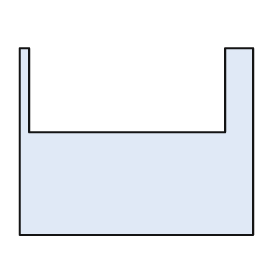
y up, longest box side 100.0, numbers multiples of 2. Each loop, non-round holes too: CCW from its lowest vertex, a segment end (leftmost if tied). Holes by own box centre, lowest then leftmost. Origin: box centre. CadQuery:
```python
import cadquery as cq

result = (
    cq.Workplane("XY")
    .moveTo(-50.0, -40.0)
    .lineTo(50.0, -40.0)
    .lineTo(50.0, 40.0)
    .lineTo(38.0, 40.0)
    .lineTo(38.0, 4.0)
    .lineTo(-46.0, 4.0)
    .lineTo(-46.0, 40.0)
    .lineTo(-50.0, 40.0)
    .close()
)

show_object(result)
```